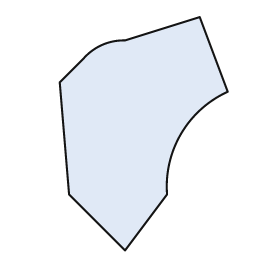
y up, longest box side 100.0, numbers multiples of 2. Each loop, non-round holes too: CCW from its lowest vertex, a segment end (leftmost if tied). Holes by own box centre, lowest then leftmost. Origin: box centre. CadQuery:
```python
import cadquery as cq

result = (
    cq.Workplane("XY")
    .moveTo(-8.0, -50.0)
    .lineTo(10.0, -26.0)
    .threePointArc((16.0, 0.0), (36.0, 18.0))
    .lineTo(24.0, 50.0)
    .lineTo(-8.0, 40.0)
    .threePointArc((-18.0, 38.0), (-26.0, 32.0))
    .lineTo(-36.0, 22.0)
    .lineTo(-32.0, -26.0)
    .close()
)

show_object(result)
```